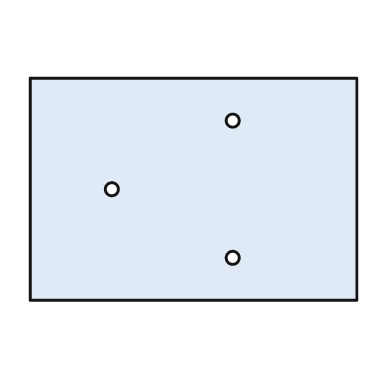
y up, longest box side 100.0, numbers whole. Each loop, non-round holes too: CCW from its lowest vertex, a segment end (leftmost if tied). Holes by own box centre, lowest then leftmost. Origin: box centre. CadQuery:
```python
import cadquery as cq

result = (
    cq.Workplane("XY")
    .moveTo(-50.0, -34.0)
    .lineTo(50.0, -34.0)
    .lineTo(50.0, 34.0)
    .lineTo(-50.0, 34.0)
    .close()
    .moveTo(12.0, -21.0)
    .circle(2.0)
    .moveTo(-25.0, 0.0)
    .circle(2.0)
    .moveTo(12.0, 21.0)
    .circle(2.0)
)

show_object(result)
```